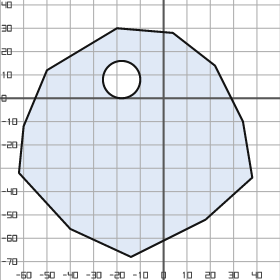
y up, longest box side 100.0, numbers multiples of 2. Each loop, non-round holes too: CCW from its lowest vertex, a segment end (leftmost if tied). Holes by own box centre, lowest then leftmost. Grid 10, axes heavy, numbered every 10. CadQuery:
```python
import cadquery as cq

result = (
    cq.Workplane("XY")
    .moveTo(-14.0, -68.0)
    .lineTo(18.0, -52.0)
    .lineTo(38.0, -34.0)
    .lineTo(34.0, -10.0)
    .lineTo(22.0, 14.0)
    .lineTo(4.0, 28.0)
    .lineTo(-20.0, 30.0)
    .lineTo(-50.0, 12.0)
    .lineTo(-60.0, -12.0)
    .lineTo(-62.0, -32.0)
    .lineTo(-40.0, -56.0)
    .close()
    .moveTo(-18.0, 8.0)
    .circle(8.0)
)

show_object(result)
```